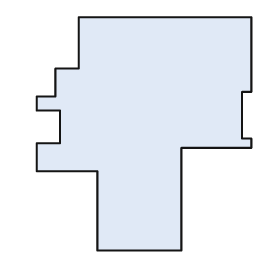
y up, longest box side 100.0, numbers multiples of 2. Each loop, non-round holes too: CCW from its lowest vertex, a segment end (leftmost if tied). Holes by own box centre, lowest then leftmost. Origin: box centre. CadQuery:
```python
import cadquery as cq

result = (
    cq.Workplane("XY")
    .moveTo(-20.0, -50.0)
    .lineTo(16.0, -50.0)
    .lineTo(16.0, -6.0)
    .lineTo(46.0, -6.0)
    .lineTo(46.0, -2.0)
    .lineTo(42.0, -2.0)
    .lineTo(42.0, 18.0)
    .lineTo(46.0, 18.0)
    .lineTo(46.0, 50.0)
    .lineTo(-28.0, 50.0)
    .lineTo(-28.0, 28.0)
    .lineTo(-38.0, 28.0)
    .lineTo(-38.0, 16.0)
    .lineTo(-46.0, 16.0)
    .lineTo(-46.0, 10.0)
    .lineTo(-36.0, 10.0)
    .lineTo(-36.0, -4.0)
    .lineTo(-46.0, -4.0)
    .lineTo(-46.0, -16.0)
    .lineTo(-20.0, -16.0)
    .close()
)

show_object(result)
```